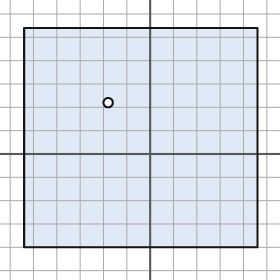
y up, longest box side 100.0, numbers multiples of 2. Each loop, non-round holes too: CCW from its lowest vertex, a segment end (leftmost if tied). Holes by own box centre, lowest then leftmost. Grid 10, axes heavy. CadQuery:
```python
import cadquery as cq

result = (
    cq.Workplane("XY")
    .moveTo(-54.0, -40.0)
    .lineTo(46.0, -40.0)
    .lineTo(46.0, 54.0)
    .lineTo(-54.0, 54.0)
    .close()
    .moveTo(-18.0, 22.0)
    .circle(2.0)
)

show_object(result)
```